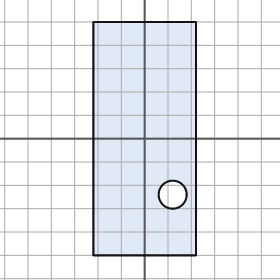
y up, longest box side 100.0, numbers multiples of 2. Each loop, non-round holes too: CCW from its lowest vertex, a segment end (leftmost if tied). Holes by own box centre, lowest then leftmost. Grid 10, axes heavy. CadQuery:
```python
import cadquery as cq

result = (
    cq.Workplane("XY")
    .moveTo(-22.0, -50.0)
    .lineTo(22.0, -50.0)
    .lineTo(22.0, 50.0)
    .lineTo(-22.0, 50.0)
    .close()
    .moveTo(12.0, -24.0)
    .circle(6.0)
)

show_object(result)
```